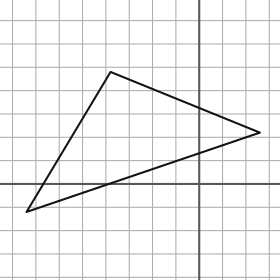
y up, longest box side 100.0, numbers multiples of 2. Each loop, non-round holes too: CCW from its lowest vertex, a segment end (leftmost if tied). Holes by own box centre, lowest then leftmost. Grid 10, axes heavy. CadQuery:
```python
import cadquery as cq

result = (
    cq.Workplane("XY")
    .moveTo(-74.0, -12.0)
    .lineTo(26.0, 22.0)
    .lineTo(-38.0, 48.0)
    .close()
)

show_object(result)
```